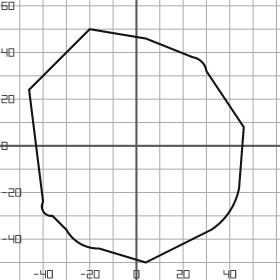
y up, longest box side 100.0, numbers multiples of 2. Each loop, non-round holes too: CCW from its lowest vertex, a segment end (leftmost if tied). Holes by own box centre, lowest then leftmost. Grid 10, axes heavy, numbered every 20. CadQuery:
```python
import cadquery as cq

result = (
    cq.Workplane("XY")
    .moveTo(4.0, -50.0)
    .lineTo(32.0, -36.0)
    .threePointArc((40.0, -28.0), (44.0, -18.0))
    .lineTo(46.0, 8.0)
    .lineTo(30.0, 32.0)
    .threePointArc((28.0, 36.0), (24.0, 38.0))
    .lineTo(4.0, 46.0)
    .lineTo(-20.0, 50.0)
    .lineTo(-46.0, 24.0)
    .lineTo(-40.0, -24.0)
    .threePointArc((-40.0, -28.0), (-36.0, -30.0))
    .lineTo(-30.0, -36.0)
    .threePointArc((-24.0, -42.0), (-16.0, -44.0))
    .close()
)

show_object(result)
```